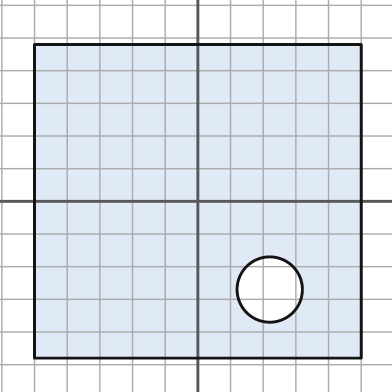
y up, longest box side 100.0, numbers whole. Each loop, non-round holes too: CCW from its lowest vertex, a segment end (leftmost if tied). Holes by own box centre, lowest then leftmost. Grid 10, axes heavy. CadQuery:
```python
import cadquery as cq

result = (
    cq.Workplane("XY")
    .moveTo(-50.0, -48.0)
    .lineTo(50.0, -48.0)
    .lineTo(50.0, 48.0)
    .lineTo(-50.0, 48.0)
    .close()
    .moveTo(22.0, -27.0)
    .circle(10.0)
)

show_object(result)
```